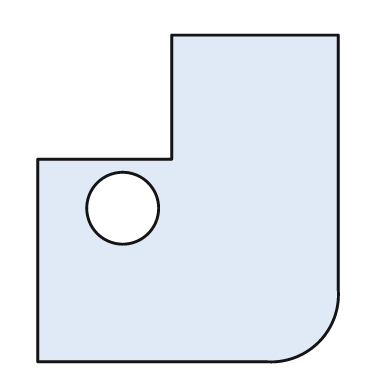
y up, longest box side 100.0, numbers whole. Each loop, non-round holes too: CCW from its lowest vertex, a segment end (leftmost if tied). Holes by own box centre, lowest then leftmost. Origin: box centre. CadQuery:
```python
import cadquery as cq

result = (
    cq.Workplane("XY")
    .moveTo(-46.0, -50.0)
    .lineTo(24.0, -50.0)
    .threePointArc((40.0, -44.0), (46.0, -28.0))
    .lineTo(46.0, 50.0)
    .lineTo(-5.0, 50.0)
    .lineTo(-5.0, 12.0)
    .lineTo(-46.0, 12.0)
    .close()
    .moveTo(-20.0, -3.0)
    .circle(11.0)
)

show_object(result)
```